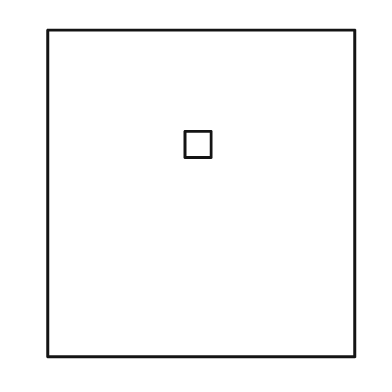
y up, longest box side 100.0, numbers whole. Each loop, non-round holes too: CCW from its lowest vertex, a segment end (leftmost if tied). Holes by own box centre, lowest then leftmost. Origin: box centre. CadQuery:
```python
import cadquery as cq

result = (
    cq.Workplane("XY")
    .moveTo(-47.0, -50.0)
    .lineTo(47.0, -50.0)
    .lineTo(47.0, 50.0)
    .lineTo(-47.0, 50.0)
    .close()
    .moveTo(-5.0, 11.0)
    .lineTo(3.0, 11.0)
    .lineTo(3.0, 19.0)
    .lineTo(-5.0, 19.0)
    .close()
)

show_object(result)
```